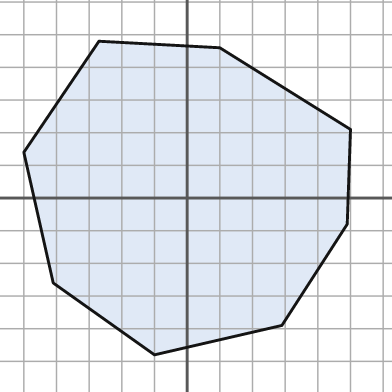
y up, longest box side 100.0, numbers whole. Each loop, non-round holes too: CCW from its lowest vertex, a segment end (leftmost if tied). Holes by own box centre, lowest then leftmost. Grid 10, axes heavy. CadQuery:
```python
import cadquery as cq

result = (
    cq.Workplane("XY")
    .moveTo(-10.0, -48.0)
    .lineTo(29.0, -39.0)
    .lineTo(49.0, -8.0)
    .lineTo(50.0, 21.0)
    .lineTo(10.0, 46.0)
    .lineTo(-27.0, 48.0)
    .lineTo(-50.0, 14.0)
    .lineTo(-41.0, -26.0)
    .close()
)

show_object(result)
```